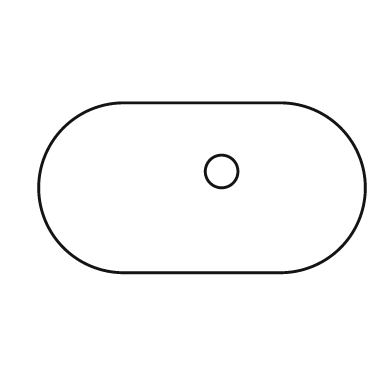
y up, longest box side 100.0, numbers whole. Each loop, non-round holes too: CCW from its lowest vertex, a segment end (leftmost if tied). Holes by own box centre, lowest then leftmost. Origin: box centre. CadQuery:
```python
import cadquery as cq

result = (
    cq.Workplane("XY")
    .moveTo(-24.0, -26.0)
    .lineTo(24.0, -26.0)
    .threePointArc((50.0, 0.0), (24.0, 26.0))
    .lineTo(-24.0, 26.0)
    .threePointArc((-50.0, 0.0), (-24.0, -26.0))
    .close()
    .moveTo(6.0, 5.0)
    .circle(5.0)
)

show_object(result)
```